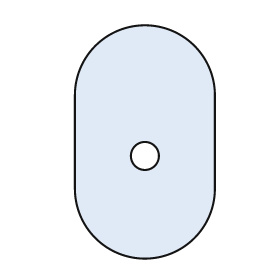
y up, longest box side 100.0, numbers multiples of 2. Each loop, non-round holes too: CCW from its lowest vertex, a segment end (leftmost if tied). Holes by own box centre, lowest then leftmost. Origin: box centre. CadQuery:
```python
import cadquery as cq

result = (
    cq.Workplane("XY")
    .moveTo(-30.0, -20.0)
    .threePointArc((0.0, -50.0), (30.0, -20.0))
    .lineTo(30.0, 20.0)
    .threePointArc((0.0, 50.0), (-30.0, 20.0))
    .close()
    .moveTo(0.0, -6.0)
    .circle(6.0)
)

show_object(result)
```